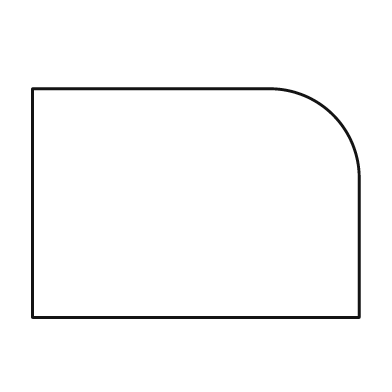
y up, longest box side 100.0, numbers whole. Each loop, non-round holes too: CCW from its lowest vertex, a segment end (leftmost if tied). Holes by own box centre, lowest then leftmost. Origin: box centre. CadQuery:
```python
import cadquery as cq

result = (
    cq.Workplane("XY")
    .moveTo(-50.0, -35.0)
    .lineTo(50.0, -35.0)
    .lineTo(50.0, 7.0)
    .threePointArc((42.0, 27.0), (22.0, 35.0))
    .lineTo(-50.0, 35.0)
    .close()
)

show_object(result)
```